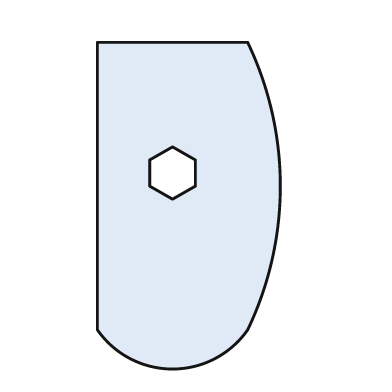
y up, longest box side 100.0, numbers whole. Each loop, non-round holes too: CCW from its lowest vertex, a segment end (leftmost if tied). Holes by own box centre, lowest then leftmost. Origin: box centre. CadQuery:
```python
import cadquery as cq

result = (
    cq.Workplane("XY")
    .moveTo(-28.0, -38.0)
    .threePointArc((-5.0, -50.0), (18.0, -38.0))
    .threePointArc((28.0, 6.0), (18.0, 50.0))
    .lineTo(-28.0, 50.0)
    .close()
    .moveTo(-5.0, 2.0)
    .lineTo(2.0, 6.0)
    .lineTo(2.0, 14.0)
    .lineTo(-5.0, 18.0)
    .lineTo(-12.0, 14.0)
    .lineTo(-12.0, 6.0)
    .close()
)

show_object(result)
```